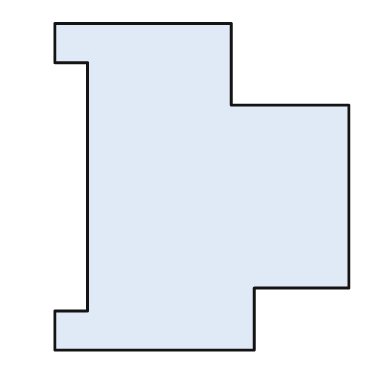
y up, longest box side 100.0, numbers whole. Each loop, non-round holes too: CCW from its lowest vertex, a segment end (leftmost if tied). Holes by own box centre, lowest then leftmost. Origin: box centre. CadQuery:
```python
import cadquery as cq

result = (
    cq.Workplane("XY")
    .moveTo(-45.0, -50.0)
    .lineTo(16.0, -50.0)
    .lineTo(16.0, -31.0)
    .lineTo(45.0, -31.0)
    .lineTo(45.0, 25.0)
    .lineTo(9.0, 25.0)
    .lineTo(9.0, 50.0)
    .lineTo(-45.0, 50.0)
    .lineTo(-45.0, 38.0)
    .lineTo(-35.0, 38.0)
    .lineTo(-35.0, -38.0)
    .lineTo(-45.0, -38.0)
    .close()
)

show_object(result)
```